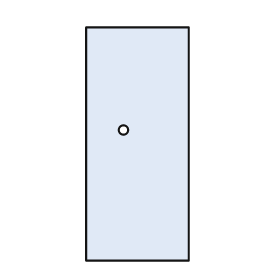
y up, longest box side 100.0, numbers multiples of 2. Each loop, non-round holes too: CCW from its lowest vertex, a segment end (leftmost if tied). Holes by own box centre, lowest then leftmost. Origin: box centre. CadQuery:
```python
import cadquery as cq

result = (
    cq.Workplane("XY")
    .moveTo(-22.0, -50.0)
    .lineTo(22.0, -50.0)
    .lineTo(22.0, 50.0)
    .lineTo(-22.0, 50.0)
    .close()
    .moveTo(-6.0, 6.0)
    .circle(2.0)
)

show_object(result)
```